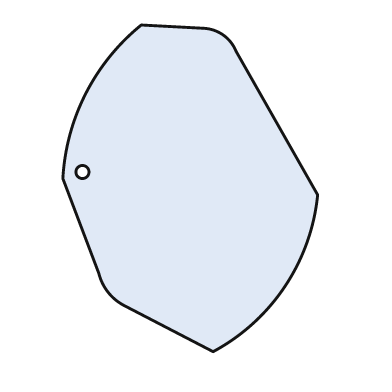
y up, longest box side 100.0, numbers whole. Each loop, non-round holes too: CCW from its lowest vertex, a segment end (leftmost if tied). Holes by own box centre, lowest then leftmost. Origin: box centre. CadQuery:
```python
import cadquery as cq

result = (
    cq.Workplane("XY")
    .moveTo(7.0, -50.0)
    .threePointArc((29.0, -30.0), (39.0, -2.0))
    .lineTo(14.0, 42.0)
    .threePointArc((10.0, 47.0), (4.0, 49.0))
    .lineTo(-15.0, 50.0)
    .threePointArc((-32.0, 29.0), (-39.0, 3.0))
    .lineTo(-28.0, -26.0)
    .threePointArc((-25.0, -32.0), (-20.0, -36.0))
    .close()
    .moveTo(-33.0, 5.0)
    .circle(2.0)
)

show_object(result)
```